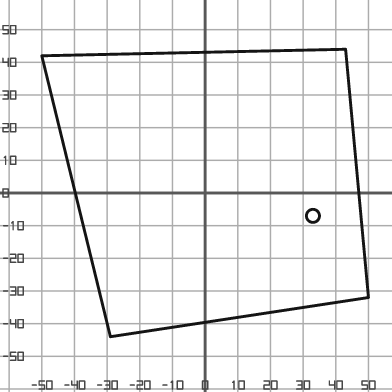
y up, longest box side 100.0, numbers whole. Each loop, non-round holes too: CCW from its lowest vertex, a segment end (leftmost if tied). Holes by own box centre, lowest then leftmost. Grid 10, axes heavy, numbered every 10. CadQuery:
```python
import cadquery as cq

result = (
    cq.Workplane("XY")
    .moveTo(-29.0, -44.0)
    .lineTo(50.0, -32.0)
    .lineTo(43.0, 44.0)
    .lineTo(-50.0, 42.0)
    .close()
    .moveTo(33.0, -7.0)
    .circle(2.0)
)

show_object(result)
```